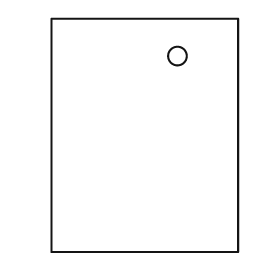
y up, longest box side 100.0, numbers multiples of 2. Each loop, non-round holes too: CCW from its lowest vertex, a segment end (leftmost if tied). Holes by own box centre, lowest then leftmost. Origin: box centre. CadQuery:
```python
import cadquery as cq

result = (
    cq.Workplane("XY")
    .moveTo(-40.0, -50.0)
    .lineTo(40.0, -50.0)
    .lineTo(40.0, 50.0)
    .lineTo(-40.0, 50.0)
    .close()
    .moveTo(14.0, 34.0)
    .circle(4.0)
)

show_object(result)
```